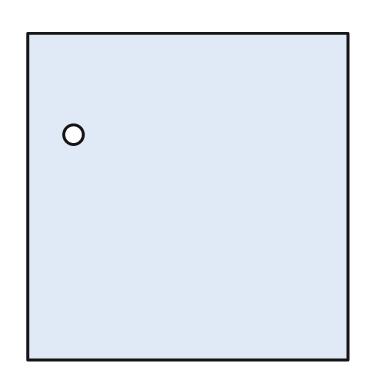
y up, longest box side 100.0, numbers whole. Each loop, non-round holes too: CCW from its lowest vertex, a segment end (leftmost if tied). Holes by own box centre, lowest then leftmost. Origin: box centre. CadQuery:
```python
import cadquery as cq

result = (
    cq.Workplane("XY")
    .moveTo(-49.0, -50.0)
    .lineTo(49.0, -50.0)
    .lineTo(49.0, 50.0)
    .lineTo(-49.0, 50.0)
    .close()
    .moveTo(-35.0, 19.0)
    .circle(3.0)
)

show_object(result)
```